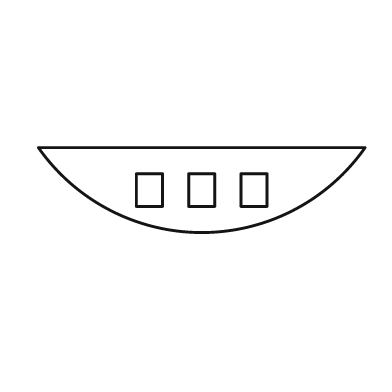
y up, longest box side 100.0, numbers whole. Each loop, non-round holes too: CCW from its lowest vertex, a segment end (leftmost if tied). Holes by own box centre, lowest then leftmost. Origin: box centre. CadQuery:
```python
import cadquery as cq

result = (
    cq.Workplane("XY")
    .moveTo(-50.0, 13.0)
    .threePointArc((0.0, -13.0), (50.0, 13.0))
    .close()
    .moveTo(-20.0, -5.0)
    .lineTo(-12.0, -5.0)
    .lineTo(-12.0, 5.0)
    .lineTo(-20.0, 5.0)
    .close()
    .moveTo(-4.0, -5.0)
    .lineTo(4.0, -5.0)
    .lineTo(4.0, 5.0)
    .lineTo(-4.0, 5.0)
    .close()
    .moveTo(12.0, -5.0)
    .lineTo(20.0, -5.0)
    .lineTo(20.0, 5.0)
    .lineTo(12.0, 5.0)
    .close()
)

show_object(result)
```